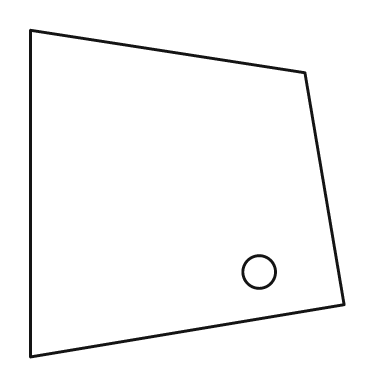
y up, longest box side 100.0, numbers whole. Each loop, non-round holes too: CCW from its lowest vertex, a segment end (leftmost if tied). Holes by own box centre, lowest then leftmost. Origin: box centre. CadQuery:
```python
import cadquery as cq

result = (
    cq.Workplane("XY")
    .moveTo(-48.0, -50.0)
    .lineTo(48.0, -34.0)
    .lineTo(36.0, 37.0)
    .lineTo(-48.0, 50.0)
    .close()
    .moveTo(22.0, -24.0)
    .circle(5.0)
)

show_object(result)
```